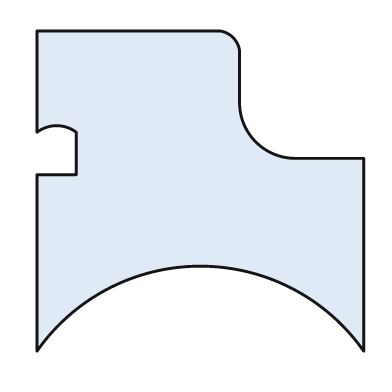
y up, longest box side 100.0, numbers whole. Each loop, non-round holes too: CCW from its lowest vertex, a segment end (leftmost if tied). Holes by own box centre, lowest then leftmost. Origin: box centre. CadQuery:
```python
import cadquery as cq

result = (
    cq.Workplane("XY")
    .moveTo(-50.0, -49.0)
    .threePointArc((0.0, -23.0), (50.0, -49.0))
    .lineTo(50.0, 10.0)
    .lineTo(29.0, 10.0)
    .threePointArc((17.0, 15.0), (12.0, 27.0))
    .lineTo(12.0, 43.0)
    .threePointArc((10.0, 47.0), (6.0, 49.0))
    .lineTo(-50.0, 49.0)
    .lineTo(-50.0, 18.0)
    .threePointArc((-44.0, 20.0), (-38.0, 18.0))
    .lineTo(-38.0, 5.0)
    .lineTo(-50.0, 5.0)
    .close()
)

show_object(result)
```